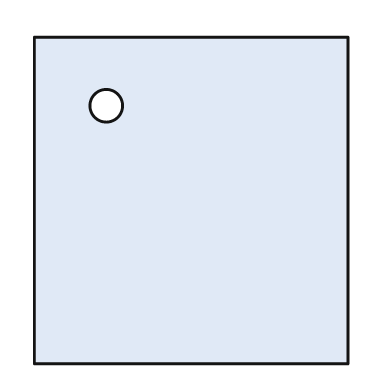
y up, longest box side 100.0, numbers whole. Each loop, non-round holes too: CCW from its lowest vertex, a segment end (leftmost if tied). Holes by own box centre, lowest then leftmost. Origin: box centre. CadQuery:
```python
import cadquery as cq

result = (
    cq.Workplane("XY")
    .moveTo(-48.0, -50.0)
    .lineTo(48.0, -50.0)
    .lineTo(48.0, 50.0)
    .lineTo(-48.0, 50.0)
    .close()
    .moveTo(-26.0, 29.0)
    .circle(5.0)
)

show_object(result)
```